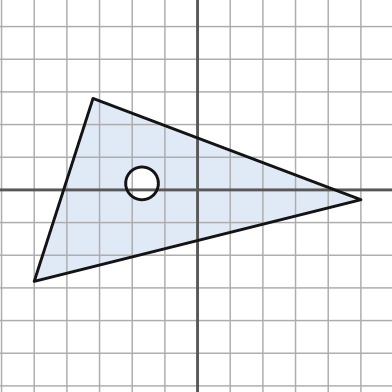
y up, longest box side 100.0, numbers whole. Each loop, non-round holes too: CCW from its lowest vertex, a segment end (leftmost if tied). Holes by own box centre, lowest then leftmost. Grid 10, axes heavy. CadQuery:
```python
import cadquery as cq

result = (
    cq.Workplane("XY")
    .moveTo(-50.0, -28.0)
    .lineTo(50.0, -3.0)
    .lineTo(-32.0, 28.0)
    .close()
    .moveTo(-17.0, 2.0)
    .circle(5.0)
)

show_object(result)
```